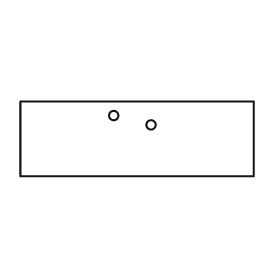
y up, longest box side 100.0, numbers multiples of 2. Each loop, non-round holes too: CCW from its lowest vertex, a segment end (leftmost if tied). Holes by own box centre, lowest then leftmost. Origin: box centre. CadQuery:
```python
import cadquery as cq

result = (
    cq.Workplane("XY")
    .moveTo(-50.0, -16.0)
    .lineTo(50.0, -16.0)
    .lineTo(50.0, 16.0)
    .lineTo(-50.0, 16.0)
    .close()
    .moveTo(6.0, 6.0)
    .circle(2.0)
    .moveTo(-10.0, 10.0)
    .circle(2.0)
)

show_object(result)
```